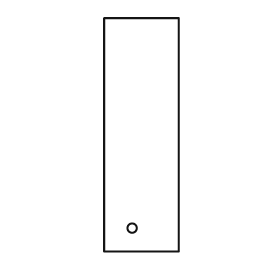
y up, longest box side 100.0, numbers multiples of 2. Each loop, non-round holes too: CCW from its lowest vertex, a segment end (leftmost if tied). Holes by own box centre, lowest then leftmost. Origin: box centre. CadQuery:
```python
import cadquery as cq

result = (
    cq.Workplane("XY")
    .moveTo(-16.0, -50.0)
    .lineTo(16.0, -50.0)
    .lineTo(16.0, 50.0)
    .lineTo(-16.0, 50.0)
    .close()
    .moveTo(-4.0, -40.0)
    .circle(2.0)
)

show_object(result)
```